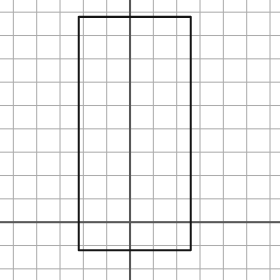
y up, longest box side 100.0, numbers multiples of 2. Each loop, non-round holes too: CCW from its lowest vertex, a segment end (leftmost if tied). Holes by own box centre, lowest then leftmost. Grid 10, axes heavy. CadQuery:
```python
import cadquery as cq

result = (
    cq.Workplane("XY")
    .moveTo(-22.0, -12.0)
    .lineTo(26.0, -12.0)
    .lineTo(26.0, 88.0)
    .lineTo(-22.0, 88.0)
    .close()
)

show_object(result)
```